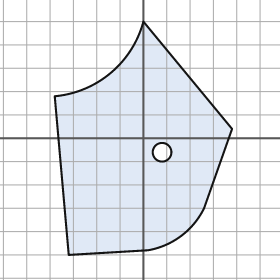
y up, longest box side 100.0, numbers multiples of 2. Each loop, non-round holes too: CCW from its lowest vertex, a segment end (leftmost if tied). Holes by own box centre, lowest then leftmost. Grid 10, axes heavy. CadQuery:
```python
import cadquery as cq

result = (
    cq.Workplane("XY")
    .moveTo(-32.0, -50.0)
    .lineTo(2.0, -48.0)
    .threePointArc((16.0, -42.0), (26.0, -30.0))
    .lineTo(38.0, 4.0)
    .lineTo(0.0, 50.0)
    .threePointArc((-14.0, 28.0), (-38.0, 18.0))
    .close()
    .moveTo(8.0, -6.0)
    .circle(4.0)
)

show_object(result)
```